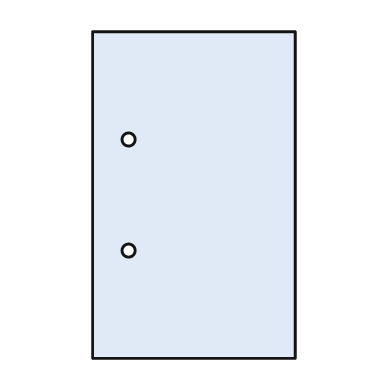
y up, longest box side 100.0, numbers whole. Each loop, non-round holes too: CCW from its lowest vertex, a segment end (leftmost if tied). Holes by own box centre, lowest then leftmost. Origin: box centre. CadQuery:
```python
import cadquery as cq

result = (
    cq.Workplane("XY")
    .moveTo(-31.0, -50.0)
    .lineTo(31.0, -50.0)
    .lineTo(31.0, 50.0)
    .lineTo(-31.0, 50.0)
    .close()
    .moveTo(-20.0, -17.0)
    .circle(2.0)
    .moveTo(-20.0, 17.0)
    .circle(2.0)
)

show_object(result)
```